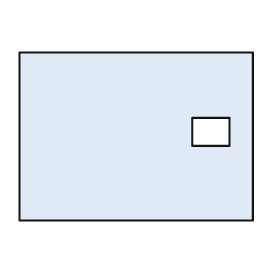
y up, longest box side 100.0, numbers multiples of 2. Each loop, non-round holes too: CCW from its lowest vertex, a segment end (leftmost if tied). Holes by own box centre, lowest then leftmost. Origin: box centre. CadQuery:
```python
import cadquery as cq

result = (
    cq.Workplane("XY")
    .moveTo(-50.0, -36.0)
    .lineTo(50.0, -36.0)
    .lineTo(50.0, 36.0)
    .lineTo(-50.0, 36.0)
    .close()
    .moveTo(24.0, -4.0)
    .lineTo(40.0, -4.0)
    .lineTo(40.0, 8.0)
    .lineTo(24.0, 8.0)
    .close()
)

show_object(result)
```